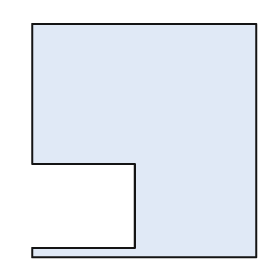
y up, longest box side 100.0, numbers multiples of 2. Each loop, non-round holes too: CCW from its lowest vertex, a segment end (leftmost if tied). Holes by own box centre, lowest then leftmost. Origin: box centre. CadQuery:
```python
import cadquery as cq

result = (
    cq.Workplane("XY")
    .moveTo(-48.0, -50.0)
    .lineTo(48.0, -50.0)
    .lineTo(48.0, 50.0)
    .lineTo(-48.0, 50.0)
    .lineTo(-48.0, -10.0)
    .lineTo(-4.0, -10.0)
    .lineTo(-4.0, -46.0)
    .lineTo(-48.0, -46.0)
    .close()
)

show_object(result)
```